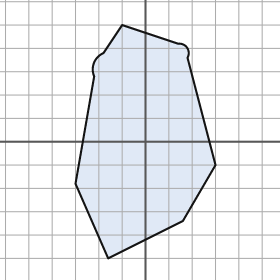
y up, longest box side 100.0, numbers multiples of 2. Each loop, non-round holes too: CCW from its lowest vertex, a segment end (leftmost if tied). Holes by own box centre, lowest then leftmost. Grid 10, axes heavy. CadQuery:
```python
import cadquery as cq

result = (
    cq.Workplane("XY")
    .moveTo(-16.0, -50.0)
    .lineTo(16.0, -34.0)
    .lineTo(30.0, -10.0)
    .lineTo(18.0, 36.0)
    .threePointArc((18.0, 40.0), (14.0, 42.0))
    .lineTo(-10.0, 50.0)
    .lineTo(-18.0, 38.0)
    .threePointArc((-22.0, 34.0), (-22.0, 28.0))
    .lineTo(-30.0, -18.0)
    .close()
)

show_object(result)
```